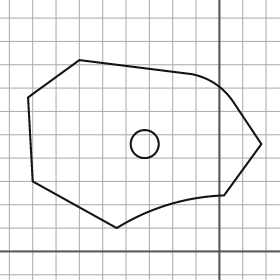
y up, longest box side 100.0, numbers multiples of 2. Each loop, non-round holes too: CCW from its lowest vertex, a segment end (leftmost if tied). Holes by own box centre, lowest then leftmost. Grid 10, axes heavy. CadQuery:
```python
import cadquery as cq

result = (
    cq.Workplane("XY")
    .moveTo(-44.0, 10.0)
    .threePointArc((-22.0, 20.0), (2.0, 24.0))
    .lineTo(18.0, 46.0)
    .lineTo(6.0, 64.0)
    .threePointArc((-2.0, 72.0), (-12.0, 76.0))
    .lineTo(-60.0, 82.0)
    .lineTo(-82.0, 66.0)
    .lineTo(-80.0, 30.0)
    .close()
    .moveTo(-32.0, 46.0)
    .circle(6.0)
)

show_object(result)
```